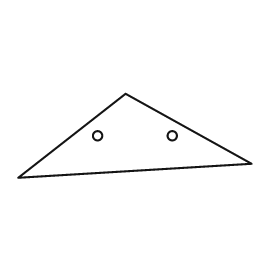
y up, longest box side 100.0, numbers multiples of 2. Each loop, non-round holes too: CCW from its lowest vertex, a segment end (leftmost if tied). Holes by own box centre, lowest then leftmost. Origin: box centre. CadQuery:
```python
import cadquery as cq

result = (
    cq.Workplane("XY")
    .moveTo(-50.0, -18.0)
    .lineTo(50.0, -12.0)
    .lineTo(-4.0, 18.0)
    .close()
    .moveTo(-16.0, 0.0)
    .circle(2.0)
    .moveTo(16.0, 0.0)
    .circle(2.0)
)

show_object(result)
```